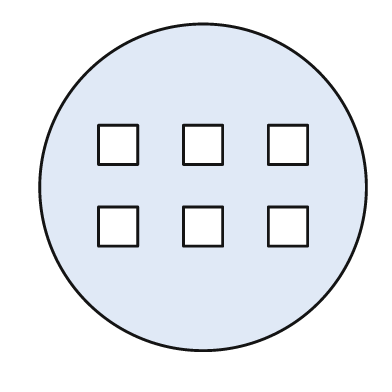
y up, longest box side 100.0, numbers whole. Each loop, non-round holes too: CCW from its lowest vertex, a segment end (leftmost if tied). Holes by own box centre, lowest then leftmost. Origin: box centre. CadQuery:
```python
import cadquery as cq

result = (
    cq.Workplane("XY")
    .moveTo(0.0, 0.0)
    .circle(50.0)
    .moveTo(-32.0, -18.0)
    .lineTo(-20.0, -18.0)
    .lineTo(-20.0, -6.0)
    .lineTo(-32.0, -6.0)
    .close()
    .moveTo(-6.0, -18.0)
    .lineTo(6.0, -18.0)
    .lineTo(6.0, -6.0)
    .lineTo(-6.0, -6.0)
    .close()
    .moveTo(20.0, -18.0)
    .lineTo(32.0, -18.0)
    .lineTo(32.0, -6.0)
    .lineTo(20.0, -6.0)
    .close()
    .moveTo(-32.0, 7.0)
    .lineTo(-20.0, 7.0)
    .lineTo(-20.0, 19.0)
    .lineTo(-32.0, 19.0)
    .close()
    .moveTo(-6.0, 7.0)
    .lineTo(6.0, 7.0)
    .lineTo(6.0, 19.0)
    .lineTo(-6.0, 19.0)
    .close()
    .moveTo(20.0, 7.0)
    .lineTo(32.0, 7.0)
    .lineTo(32.0, 19.0)
    .lineTo(20.0, 19.0)
    .close()
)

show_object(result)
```